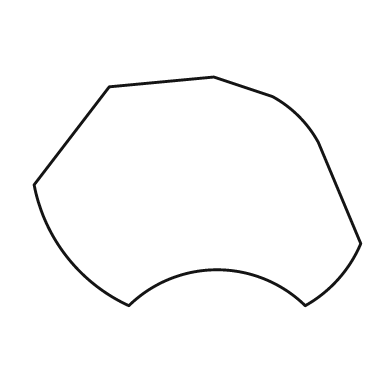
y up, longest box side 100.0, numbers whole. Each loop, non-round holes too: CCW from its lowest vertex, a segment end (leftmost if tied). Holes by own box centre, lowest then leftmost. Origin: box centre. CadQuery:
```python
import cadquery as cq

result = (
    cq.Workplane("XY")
    .moveTo(-21.0, -35.0)
    .threePointArc((6.0, -24.0), (33.0, -35.0))
    .threePointArc((43.0, -27.0), (50.0, -16.0))
    .lineTo(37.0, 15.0)
    .threePointArc((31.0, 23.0), (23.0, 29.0))
    .lineTo(5.0, 35.0)
    .lineTo(-27.0, 32.0)
    .lineTo(-50.0, 2.0)
    .threePointArc((-40.0, -20.0), (-21.0, -35.0))
    .close()
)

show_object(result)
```